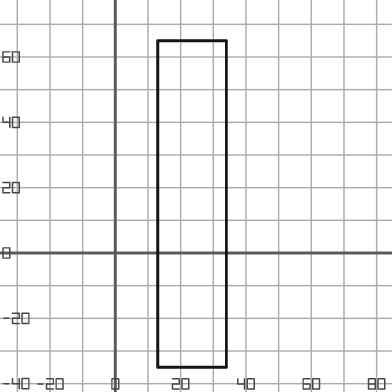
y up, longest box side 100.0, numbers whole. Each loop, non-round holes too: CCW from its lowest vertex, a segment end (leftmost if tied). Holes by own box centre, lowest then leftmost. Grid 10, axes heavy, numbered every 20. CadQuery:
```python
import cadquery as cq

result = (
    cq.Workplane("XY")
    .moveTo(13.0, -35.0)
    .lineTo(34.0, -35.0)
    .lineTo(34.0, 65.0)
    .lineTo(13.0, 65.0)
    .close()
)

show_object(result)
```